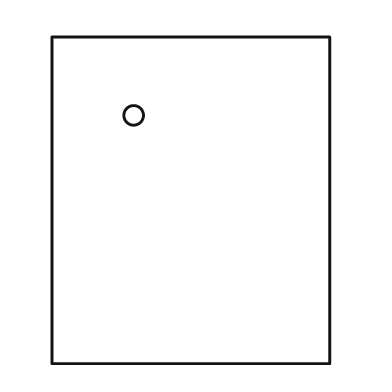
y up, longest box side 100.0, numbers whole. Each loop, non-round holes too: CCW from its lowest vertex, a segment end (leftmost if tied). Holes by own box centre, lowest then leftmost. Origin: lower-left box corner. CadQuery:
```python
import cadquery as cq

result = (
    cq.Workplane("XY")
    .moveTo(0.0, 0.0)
    .lineTo(85.0, 0.0)
    .lineTo(85.0, 100.0)
    .lineTo(0.0, 100.0)
    .close()
    .moveTo(25.0, 76.0)
    .circle(3.0)
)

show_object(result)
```